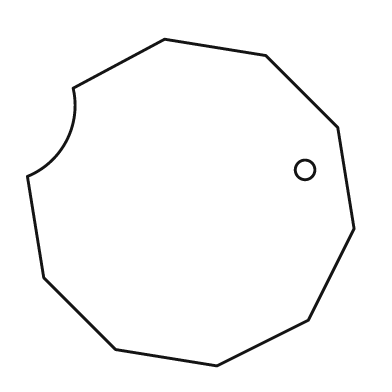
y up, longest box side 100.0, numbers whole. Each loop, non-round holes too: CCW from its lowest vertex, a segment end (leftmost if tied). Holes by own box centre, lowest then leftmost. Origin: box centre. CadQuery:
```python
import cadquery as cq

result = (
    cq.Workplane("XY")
    .moveTo(8.0, -50.0)
    .lineTo(36.0, -36.0)
    .lineTo(50.0, -8.0)
    .lineTo(45.0, 23.0)
    .lineTo(23.0, 45.0)
    .lineTo(-8.0, 50.0)
    .lineTo(-36.0, 35.0)
    .threePointArc((-38.0, 19.0), (-50.0, 8.0))
    .lineTo(-45.0, -23.0)
    .lineTo(-23.0, -45.0)
    .close()
    .moveTo(35.0, 10.0)
    .circle(3.0)
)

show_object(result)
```